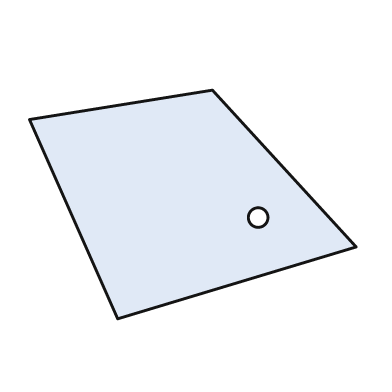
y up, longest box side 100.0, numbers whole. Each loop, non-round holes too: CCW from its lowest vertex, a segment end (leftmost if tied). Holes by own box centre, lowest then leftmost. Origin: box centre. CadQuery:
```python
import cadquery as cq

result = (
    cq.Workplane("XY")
    .moveTo(-23.0, -35.0)
    .lineTo(50.0, -13.0)
    .lineTo(6.0, 35.0)
    .lineTo(-50.0, 26.0)
    .close()
    .moveTo(20.0, -4.0)
    .circle(3.0)
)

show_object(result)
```